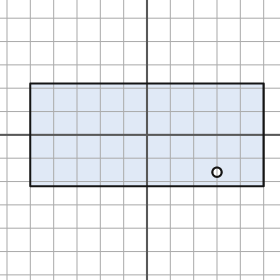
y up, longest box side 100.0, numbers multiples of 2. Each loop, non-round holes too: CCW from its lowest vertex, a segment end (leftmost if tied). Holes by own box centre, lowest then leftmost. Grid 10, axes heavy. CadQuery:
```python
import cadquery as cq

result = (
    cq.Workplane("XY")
    .moveTo(-50.0, -22.0)
    .lineTo(50.0, -22.0)
    .lineTo(50.0, 22.0)
    .lineTo(-50.0, 22.0)
    .close()
    .moveTo(30.0, -16.0)
    .circle(2.0)
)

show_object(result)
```